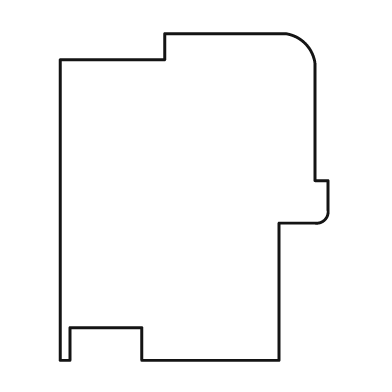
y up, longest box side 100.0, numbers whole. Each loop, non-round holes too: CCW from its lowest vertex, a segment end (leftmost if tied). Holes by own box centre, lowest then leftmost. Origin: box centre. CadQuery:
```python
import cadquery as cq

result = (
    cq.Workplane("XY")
    .moveTo(-41.0, -50.0)
    .lineTo(-38.0, -50.0)
    .lineTo(-38.0, -40.0)
    .lineTo(-16.0, -40.0)
    .lineTo(-16.0, -50.0)
    .lineTo(26.0, -50.0)
    .lineTo(26.0, -8.0)
    .lineTo(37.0, -8.0)
    .threePointArc((40.0, -7.0), (41.0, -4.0))
    .lineTo(41.0, 5.0)
    .lineTo(37.0, 5.0)
    .lineTo(37.0, 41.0)
    .threePointArc((34.0, 47.0), (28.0, 50.0))
    .lineTo(-9.0, 50.0)
    .lineTo(-9.0, 42.0)
    .lineTo(-41.0, 42.0)
    .close()
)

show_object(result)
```